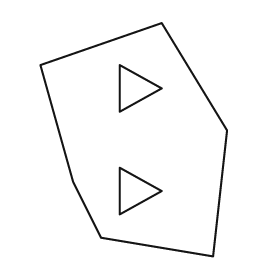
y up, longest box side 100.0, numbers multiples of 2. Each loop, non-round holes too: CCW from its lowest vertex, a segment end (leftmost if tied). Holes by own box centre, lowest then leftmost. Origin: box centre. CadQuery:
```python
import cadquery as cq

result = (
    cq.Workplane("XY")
    .moveTo(34.0, -50.0)
    .lineTo(40.0, 4.0)
    .lineTo(12.0, 50.0)
    .lineTo(-40.0, 32.0)
    .lineTo(-26.0, -18.0)
    .lineTo(-14.0, -42.0)
    .close()
    .moveTo(-6.0, -32.0)
    .lineTo(12.0, -22.0)
    .lineTo(-6.0, -12.0)
    .close()
    .moveTo(-6.0, 12.0)
    .lineTo(12.0, 22.0)
    .lineTo(-6.0, 32.0)
    .close()
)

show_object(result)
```